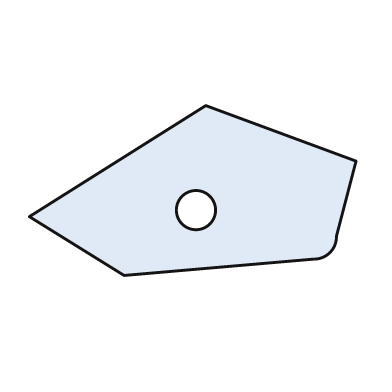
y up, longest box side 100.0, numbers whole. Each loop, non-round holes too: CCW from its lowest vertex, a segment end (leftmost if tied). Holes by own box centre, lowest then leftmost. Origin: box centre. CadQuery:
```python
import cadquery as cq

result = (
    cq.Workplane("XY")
    .moveTo(-21.0, -26.0)
    .lineTo(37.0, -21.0)
    .threePointArc((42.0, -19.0), (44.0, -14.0))
    .lineTo(50.0, 9.0)
    .lineTo(4.0, 26.0)
    .lineTo(-50.0, -8.0)
    .close()
    .moveTo(1.0, -6.0)
    .circle(6.0)
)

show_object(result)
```